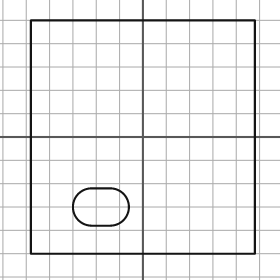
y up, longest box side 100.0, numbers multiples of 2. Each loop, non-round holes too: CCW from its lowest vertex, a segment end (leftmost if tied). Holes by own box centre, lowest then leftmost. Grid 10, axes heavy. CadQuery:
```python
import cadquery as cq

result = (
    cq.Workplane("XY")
    .moveTo(-48.0, -50.0)
    .lineTo(48.0, -50.0)
    .lineTo(48.0, 50.0)
    .lineTo(-48.0, 50.0)
    .close()
    .moveTo(-22.0, -38.0)
    .lineTo(-14.0, -38.0)
    .threePointArc((-6.0, -30.0), (-14.0, -22.0))
    .lineTo(-22.0, -22.0)
    .threePointArc((-30.0, -30.0), (-22.0, -38.0))
    .close()
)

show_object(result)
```